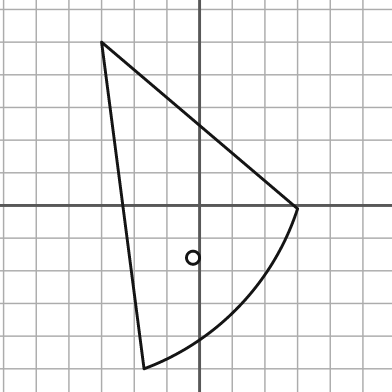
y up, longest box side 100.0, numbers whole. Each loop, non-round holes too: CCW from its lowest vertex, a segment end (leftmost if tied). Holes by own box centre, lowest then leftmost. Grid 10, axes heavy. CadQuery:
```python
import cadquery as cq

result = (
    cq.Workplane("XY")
    .moveTo(-17.0, -50.0)
    .threePointArc((12.0, -31.0), (30.0, -1.0))
    .lineTo(-30.0, 50.0)
    .close()
    .moveTo(-2.0, -16.0)
    .circle(2.0)
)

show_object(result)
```